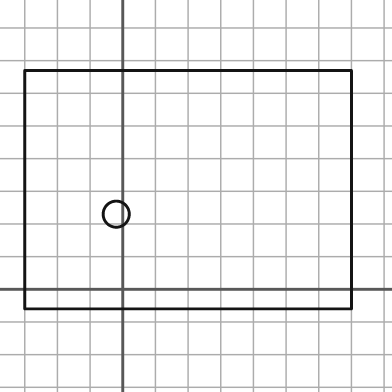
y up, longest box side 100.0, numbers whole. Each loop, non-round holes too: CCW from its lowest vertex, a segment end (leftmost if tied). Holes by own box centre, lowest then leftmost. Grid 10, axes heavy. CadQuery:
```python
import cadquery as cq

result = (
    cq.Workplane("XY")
    .moveTo(-30.0, -6.0)
    .lineTo(70.0, -6.0)
    .lineTo(70.0, 67.0)
    .lineTo(-30.0, 67.0)
    .close()
    .moveTo(-2.0, 23.0)
    .circle(4.0)
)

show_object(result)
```